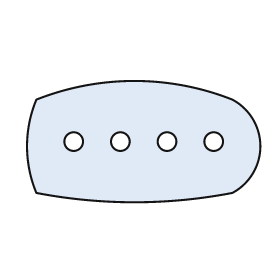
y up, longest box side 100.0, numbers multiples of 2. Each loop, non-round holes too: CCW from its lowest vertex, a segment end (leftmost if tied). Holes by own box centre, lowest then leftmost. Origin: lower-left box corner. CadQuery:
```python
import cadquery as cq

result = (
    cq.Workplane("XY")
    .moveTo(4.0, 4.0)
    .threePointArc((46.0, 0.0), (88.0, 4.0))
    .threePointArc((100.0, 24.0), (88.0, 44.0))
    .threePointArc((46.0, 52.0), (4.0, 44.0))
    .threePointArc((0.0, 24.0), (4.0, 4.0))
    .close()
    .moveTo(20.0, 26.0)
    .circle(4.0)
    .moveTo(40.0, 26.0)
    .circle(4.0)
    .moveTo(60.0, 26.0)
    .circle(4.0)
    .moveTo(80.0, 26.0)
    .circle(4.0)
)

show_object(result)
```